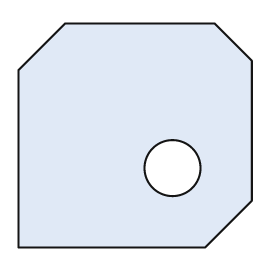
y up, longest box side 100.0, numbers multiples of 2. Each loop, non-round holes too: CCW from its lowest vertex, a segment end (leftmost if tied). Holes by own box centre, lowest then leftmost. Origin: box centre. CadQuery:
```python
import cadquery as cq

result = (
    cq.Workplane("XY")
    .moveTo(-50.0, -48.0)
    .lineTo(30.0, -48.0)
    .lineTo(50.0, -28.0)
    .lineTo(50.0, 32.0)
    .lineTo(34.0, 48.0)
    .lineTo(-30.0, 48.0)
    .lineTo(-50.0, 28.0)
    .close()
    .moveTo(16.0, -14.0)
    .circle(12.0)
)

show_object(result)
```